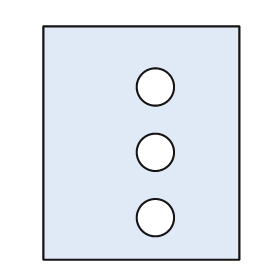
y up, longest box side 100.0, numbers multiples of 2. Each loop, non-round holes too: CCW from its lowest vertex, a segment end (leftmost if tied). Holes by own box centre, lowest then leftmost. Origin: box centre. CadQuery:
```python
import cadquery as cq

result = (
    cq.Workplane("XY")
    .moveTo(-42.0, -50.0)
    .lineTo(42.0, -50.0)
    .lineTo(42.0, 50.0)
    .lineTo(-42.0, 50.0)
    .close()
    .moveTo(6.0, -32.0)
    .circle(8.0)
    .moveTo(6.0, -4.0)
    .circle(8.0)
    .moveTo(6.0, 24.0)
    .circle(8.0)
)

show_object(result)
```